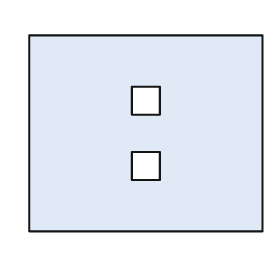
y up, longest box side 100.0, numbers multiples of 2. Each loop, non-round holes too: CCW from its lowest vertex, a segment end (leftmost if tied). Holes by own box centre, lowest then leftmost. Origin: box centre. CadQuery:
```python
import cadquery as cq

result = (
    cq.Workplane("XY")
    .moveTo(-50.0, -42.0)
    .lineTo(50.0, -42.0)
    .lineTo(50.0, 42.0)
    .lineTo(-50.0, 42.0)
    .close()
    .moveTo(-6.0, -20.0)
    .lineTo(6.0, -20.0)
    .lineTo(6.0, -8.0)
    .lineTo(-6.0, -8.0)
    .close()
    .moveTo(-6.0, 8.0)
    .lineTo(6.0, 8.0)
    .lineTo(6.0, 20.0)
    .lineTo(-6.0, 20.0)
    .close()
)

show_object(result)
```